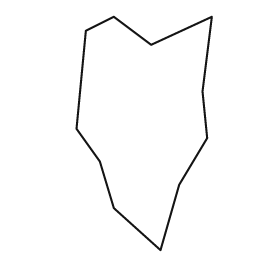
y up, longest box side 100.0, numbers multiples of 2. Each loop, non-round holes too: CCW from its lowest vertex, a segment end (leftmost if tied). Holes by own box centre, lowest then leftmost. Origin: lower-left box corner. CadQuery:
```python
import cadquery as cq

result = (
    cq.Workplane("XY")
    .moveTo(36.0, 0.0)
    .lineTo(44.0, 28.0)
    .lineTo(56.0, 48.0)
    .lineTo(54.0, 68.0)
    .lineTo(58.0, 100.0)
    .lineTo(32.0, 88.0)
    .lineTo(16.0, 100.0)
    .lineTo(4.0, 94.0)
    .lineTo(0.0, 52.0)
    .lineTo(10.0, 38.0)
    .lineTo(16.0, 18.0)
    .close()
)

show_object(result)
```